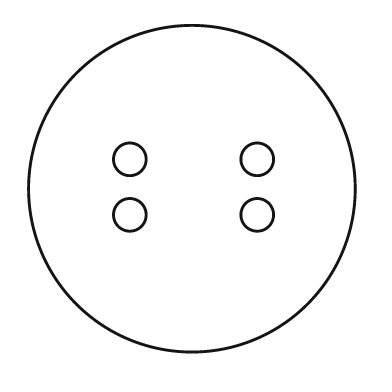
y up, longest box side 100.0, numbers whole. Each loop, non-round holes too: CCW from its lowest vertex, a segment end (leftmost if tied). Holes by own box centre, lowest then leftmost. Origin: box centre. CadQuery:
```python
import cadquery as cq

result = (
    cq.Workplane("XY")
    .moveTo(0.0, 0.0)
    .circle(50.0)
    .moveTo(-19.0, -8.0)
    .circle(5.0)
    .moveTo(20.0, -8.0)
    .circle(5.0)
    .moveTo(-19.0, 9.0)
    .circle(5.0)
    .moveTo(20.0, 9.0)
    .circle(5.0)
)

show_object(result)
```